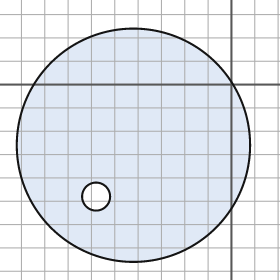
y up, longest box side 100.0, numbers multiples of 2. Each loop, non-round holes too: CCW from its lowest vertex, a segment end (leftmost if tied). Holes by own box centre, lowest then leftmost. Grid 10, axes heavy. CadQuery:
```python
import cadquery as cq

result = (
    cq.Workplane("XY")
    .moveTo(-42.0, -26.0)
    .circle(50.0)
    .moveTo(-58.0, -48.0)
    .circle(6.0)
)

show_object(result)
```